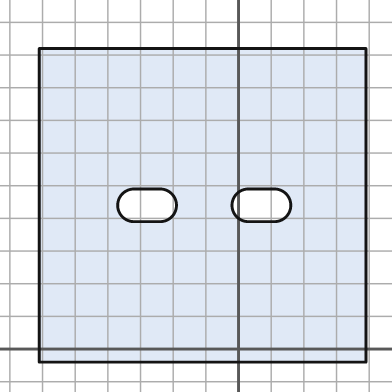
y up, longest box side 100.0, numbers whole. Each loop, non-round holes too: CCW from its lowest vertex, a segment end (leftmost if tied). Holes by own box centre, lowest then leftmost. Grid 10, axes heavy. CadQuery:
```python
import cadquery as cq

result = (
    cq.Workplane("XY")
    .moveTo(-61.0, -4.0)
    .lineTo(39.0, -4.0)
    .lineTo(39.0, 92.0)
    .lineTo(-61.0, 92.0)
    .close()
    .moveTo(-32.0, 39.0)
    .lineTo(-24.0, 39.0)
    .threePointArc((-19.0, 44.0), (-24.0, 49.0))
    .lineTo(-32.0, 49.0)
    .threePointArc((-37.0, 44.0), (-32.0, 39.0))
    .close()
    .moveTo(3.0, 39.0)
    .lineTo(11.0, 39.0)
    .threePointArc((16.0, 44.0), (11.0, 49.0))
    .lineTo(3.0, 49.0)
    .threePointArc((-2.0, 44.0), (3.0, 39.0))
    .close()
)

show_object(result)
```